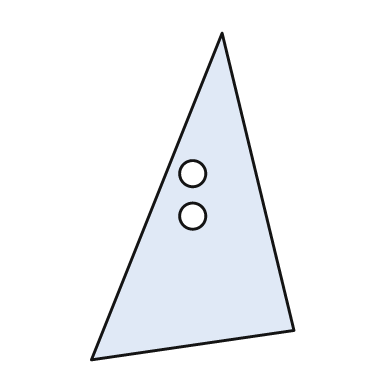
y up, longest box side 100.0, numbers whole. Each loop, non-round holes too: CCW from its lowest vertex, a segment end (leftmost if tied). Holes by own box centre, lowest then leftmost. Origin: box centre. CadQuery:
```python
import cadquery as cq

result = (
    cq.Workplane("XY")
    .moveTo(-31.0, -50.0)
    .lineTo(31.0, -41.0)
    .lineTo(9.0, 50.0)
    .close()
    .moveTo(0.0, -6.0)
    .circle(4.0)
    .moveTo(0.0, 7.0)
    .circle(4.0)
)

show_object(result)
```